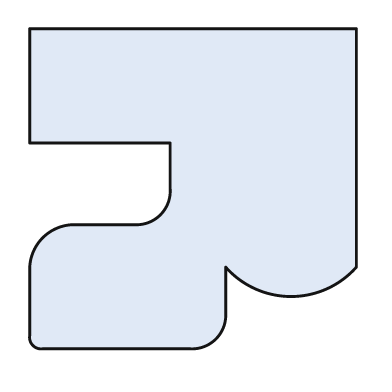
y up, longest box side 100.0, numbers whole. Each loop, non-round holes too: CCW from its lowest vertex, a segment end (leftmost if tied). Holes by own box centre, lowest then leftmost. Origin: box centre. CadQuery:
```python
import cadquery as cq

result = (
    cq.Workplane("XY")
    .moveTo(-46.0, -49.0)
    .lineTo(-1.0, -49.0)
    .threePointArc((7.0, -46.0), (10.0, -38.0))
    .lineTo(10.0, -24.0)
    .threePointArc((30.0, -33.0), (50.0, -24.0))
    .lineTo(50.0, 49.0)
    .lineTo(-50.0, 49.0)
    .lineTo(-50.0, 14.0)
    .lineTo(-7.0, 14.0)
    .lineTo(-7.0, 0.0)
    .threePointArc((-10.0, -8.0), (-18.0, -11.0))
    .lineTo(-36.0, -11.0)
    .threePointArc((-46.0, -15.0), (-50.0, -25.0))
    .lineTo(-50.0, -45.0)
    .threePointArc((-49.0, -48.0), (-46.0, -49.0))
    .close()
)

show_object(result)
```